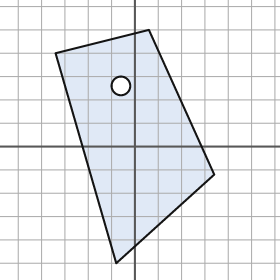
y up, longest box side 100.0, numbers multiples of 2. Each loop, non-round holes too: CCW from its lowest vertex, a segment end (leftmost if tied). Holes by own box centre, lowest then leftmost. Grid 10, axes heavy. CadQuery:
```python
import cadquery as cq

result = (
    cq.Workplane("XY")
    .moveTo(-8.0, -50.0)
    .lineTo(34.0, -12.0)
    .lineTo(6.0, 50.0)
    .lineTo(-34.0, 40.0)
    .close()
    .moveTo(-6.0, 26.0)
    .circle(4.0)
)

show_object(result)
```